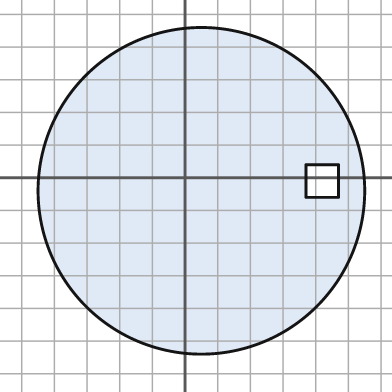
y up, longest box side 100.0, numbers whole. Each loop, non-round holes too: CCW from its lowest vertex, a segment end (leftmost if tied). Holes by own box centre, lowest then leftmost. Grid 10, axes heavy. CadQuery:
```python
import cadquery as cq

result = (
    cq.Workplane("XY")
    .moveTo(5.0, -4.0)
    .circle(50.0)
    .moveTo(37.0, -6.0)
    .lineTo(47.0, -6.0)
    .lineTo(47.0, 4.0)
    .lineTo(37.0, 4.0)
    .close()
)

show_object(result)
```